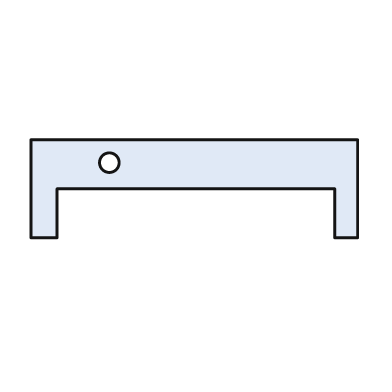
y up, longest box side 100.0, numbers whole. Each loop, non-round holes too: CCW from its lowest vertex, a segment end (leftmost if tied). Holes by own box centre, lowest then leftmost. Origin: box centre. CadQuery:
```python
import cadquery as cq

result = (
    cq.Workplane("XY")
    .moveTo(-50.0, -15.0)
    .lineTo(-42.0, -15.0)
    .lineTo(-42.0, 0.0)
    .lineTo(43.0, 0.0)
    .lineTo(43.0, -15.0)
    .lineTo(50.0, -15.0)
    .lineTo(50.0, 15.0)
    .lineTo(-50.0, 15.0)
    .close()
    .moveTo(-26.0, 8.0)
    .circle(3.0)
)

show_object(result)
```